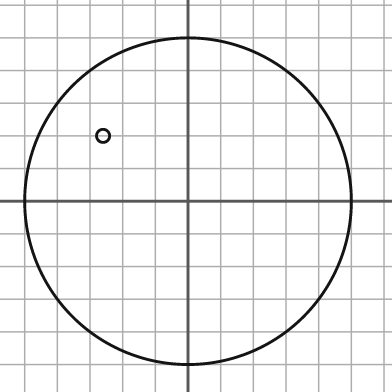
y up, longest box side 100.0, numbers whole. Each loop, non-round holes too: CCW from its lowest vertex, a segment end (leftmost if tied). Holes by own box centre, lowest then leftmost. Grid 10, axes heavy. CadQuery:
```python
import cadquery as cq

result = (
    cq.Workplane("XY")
    .moveTo(0.0, 0.0)
    .circle(50.0)
    .moveTo(-26.0, 20.0)
    .circle(2.0)
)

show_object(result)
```